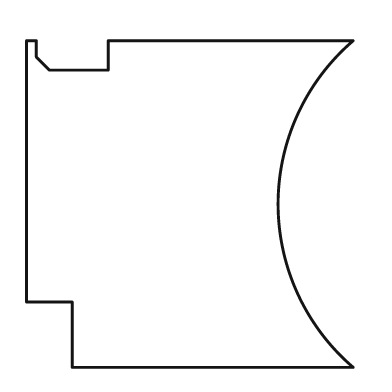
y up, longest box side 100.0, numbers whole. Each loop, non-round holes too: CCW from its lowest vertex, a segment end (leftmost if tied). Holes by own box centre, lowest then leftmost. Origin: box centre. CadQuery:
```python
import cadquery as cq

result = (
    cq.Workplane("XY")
    .moveTo(-36.0, -50.0)
    .lineTo(50.0, -50.0)
    .threePointArc((27.0, 0.0), (50.0, 50.0))
    .lineTo(-25.0, 50.0)
    .lineTo(-25.0, 41.0)
    .lineTo(-43.0, 41.0)
    .lineTo(-47.0, 45.0)
    .lineTo(-47.0, 50.0)
    .lineTo(-50.0, 50.0)
    .lineTo(-50.0, -30.0)
    .lineTo(-36.0, -30.0)
    .close()
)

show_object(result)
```